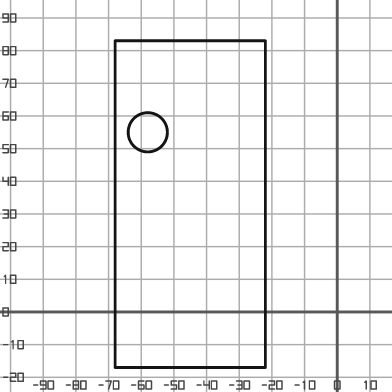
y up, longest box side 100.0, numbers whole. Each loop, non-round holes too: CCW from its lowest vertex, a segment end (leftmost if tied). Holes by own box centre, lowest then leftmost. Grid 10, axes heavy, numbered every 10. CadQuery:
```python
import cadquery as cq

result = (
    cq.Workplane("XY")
    .moveTo(-68.0, -17.0)
    .lineTo(-22.0, -17.0)
    .lineTo(-22.0, 83.0)
    .lineTo(-68.0, 83.0)
    .close()
    .moveTo(-58.0, 55.0)
    .circle(6.0)
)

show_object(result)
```